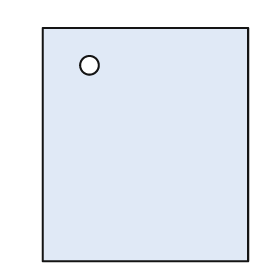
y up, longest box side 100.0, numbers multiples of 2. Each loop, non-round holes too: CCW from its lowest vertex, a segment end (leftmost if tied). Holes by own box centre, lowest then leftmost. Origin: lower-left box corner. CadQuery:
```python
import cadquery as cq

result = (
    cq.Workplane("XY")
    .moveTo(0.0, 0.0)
    .lineTo(88.0, 0.0)
    .lineTo(88.0, 100.0)
    .lineTo(0.0, 100.0)
    .close()
    .moveTo(20.0, 84.0)
    .circle(4.0)
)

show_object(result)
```